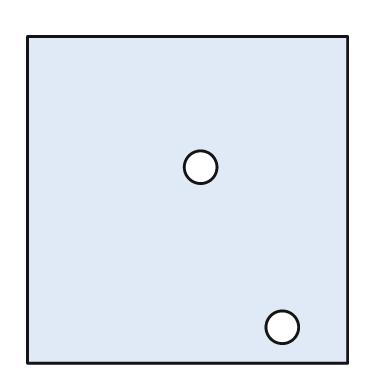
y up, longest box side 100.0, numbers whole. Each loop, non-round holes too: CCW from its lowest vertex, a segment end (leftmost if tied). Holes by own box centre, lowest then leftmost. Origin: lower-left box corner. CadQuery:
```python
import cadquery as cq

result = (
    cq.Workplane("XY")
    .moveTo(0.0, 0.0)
    .lineTo(98.0, 0.0)
    .lineTo(98.0, 100.0)
    .lineTo(0.0, 100.0)
    .close()
    .moveTo(78.0, 11.0)
    .circle(5.0)
    .moveTo(53.0, 60.0)
    .circle(5.0)
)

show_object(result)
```